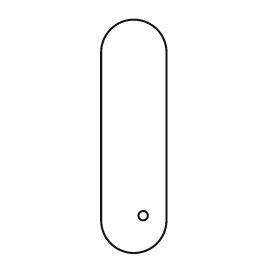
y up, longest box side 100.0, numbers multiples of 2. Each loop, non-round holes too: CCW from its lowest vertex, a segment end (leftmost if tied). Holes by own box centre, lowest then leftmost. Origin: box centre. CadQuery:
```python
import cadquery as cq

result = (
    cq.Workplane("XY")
    .moveTo(-14.0, -36.0)
    .threePointArc((0.0, -50.0), (14.0, -36.0))
    .lineTo(14.0, 36.0)
    .threePointArc((0.0, 50.0), (-14.0, 36.0))
    .close()
    .moveTo(4.0, -34.0)
    .circle(2.0)
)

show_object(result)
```